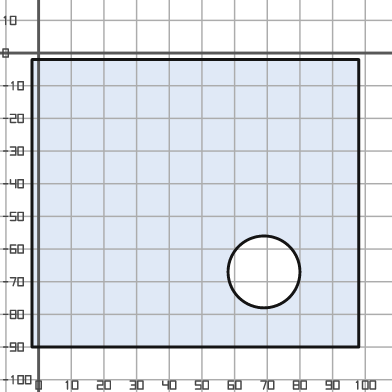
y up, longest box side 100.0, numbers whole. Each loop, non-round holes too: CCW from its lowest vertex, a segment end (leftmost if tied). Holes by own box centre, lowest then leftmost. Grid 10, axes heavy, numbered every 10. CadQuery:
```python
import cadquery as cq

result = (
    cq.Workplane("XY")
    .moveTo(-2.0, -90.0)
    .lineTo(98.0, -90.0)
    .lineTo(98.0, -2.0)
    .lineTo(-2.0, -2.0)
    .close()
    .moveTo(69.0, -67.0)
    .circle(11.0)
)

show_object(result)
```